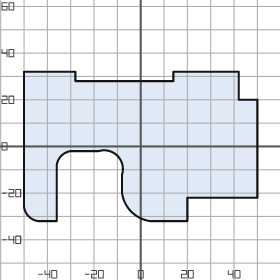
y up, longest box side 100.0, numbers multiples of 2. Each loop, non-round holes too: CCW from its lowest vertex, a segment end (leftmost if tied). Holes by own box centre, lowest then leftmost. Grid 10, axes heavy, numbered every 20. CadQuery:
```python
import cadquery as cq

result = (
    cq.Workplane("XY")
    .moveTo(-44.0, -32.0)
    .lineTo(-36.0, -32.0)
    .lineTo(-36.0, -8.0)
    .threePointArc((-34.0, -4.0), (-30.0, -2.0))
    .lineTo(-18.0, -2.0)
    .threePointArc((-10.0, -4.0), (-8.0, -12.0))
    .lineTo(-8.0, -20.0)
    .threePointArc((-4.0, -28.0), (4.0, -32.0))
    .lineTo(20.0, -32.0)
    .lineTo(20.0, -22.0)
    .lineTo(50.0, -22.0)
    .lineTo(50.0, 20.0)
    .lineTo(42.0, 20.0)
    .lineTo(42.0, 32.0)
    .lineTo(14.0, 32.0)
    .lineTo(14.0, 28.0)
    .lineTo(-28.0, 28.0)
    .lineTo(-28.0, 32.0)
    .lineTo(-50.0, 32.0)
    .lineTo(-50.0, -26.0)
    .threePointArc((-48.0, -30.0), (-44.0, -32.0))
    .close()
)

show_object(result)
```